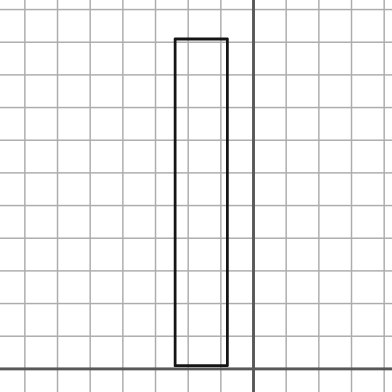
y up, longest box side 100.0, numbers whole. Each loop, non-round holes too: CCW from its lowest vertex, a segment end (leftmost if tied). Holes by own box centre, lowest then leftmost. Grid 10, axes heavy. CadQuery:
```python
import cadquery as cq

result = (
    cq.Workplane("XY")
    .moveTo(-24.0, 1.0)
    .lineTo(-8.0, 1.0)
    .lineTo(-8.0, 101.0)
    .lineTo(-24.0, 101.0)
    .close()
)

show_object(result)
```